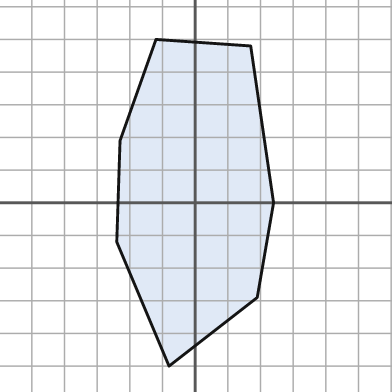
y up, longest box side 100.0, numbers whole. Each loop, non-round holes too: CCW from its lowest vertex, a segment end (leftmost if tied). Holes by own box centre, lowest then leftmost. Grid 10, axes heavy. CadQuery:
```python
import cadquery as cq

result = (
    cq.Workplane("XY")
    .moveTo(-8.0, -50.0)
    .lineTo(19.0, -29.0)
    .lineTo(24.0, 0.0)
    .lineTo(17.0, 48.0)
    .lineTo(-12.0, 50.0)
    .lineTo(-23.0, 19.0)
    .lineTo(-24.0, -12.0)
    .close()
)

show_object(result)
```